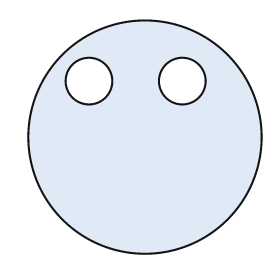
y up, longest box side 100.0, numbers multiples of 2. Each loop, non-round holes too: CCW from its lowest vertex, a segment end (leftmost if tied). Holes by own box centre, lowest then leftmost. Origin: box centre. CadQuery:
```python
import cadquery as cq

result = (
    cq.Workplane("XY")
    .moveTo(0.0, 0.0)
    .circle(50.0)
    .moveTo(-24.0, 24.0)
    .circle(10.0)
    .moveTo(16.0, 24.0)
    .circle(10.0)
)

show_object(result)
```